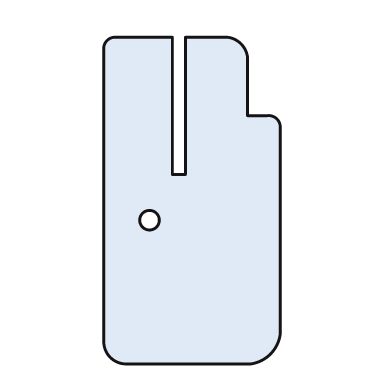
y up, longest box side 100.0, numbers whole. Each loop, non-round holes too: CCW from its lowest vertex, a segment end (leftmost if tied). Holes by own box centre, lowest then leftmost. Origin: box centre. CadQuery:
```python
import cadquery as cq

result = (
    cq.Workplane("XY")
    .moveTo(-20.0, -50.0)
    .lineTo(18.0, -50.0)
    .threePointArc((24.0, -47.0), (27.0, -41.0))
    .lineTo(27.0, 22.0)
    .threePointArc((26.0, 25.0), (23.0, 26.0))
    .lineTo(17.0, 26.0)
    .lineTo(17.0, 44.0)
    .threePointArc((15.0, 48.0), (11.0, 50.0))
    .lineTo(-2.0, 50.0)
    .lineTo(-2.0, 8.0)
    .lineTo(-6.0, 8.0)
    .lineTo(-6.0, 50.0)
    .lineTo(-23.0, 50.0)
    .threePointArc((-26.0, 49.0), (-27.0, 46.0))
    .lineTo(-27.0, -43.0)
    .threePointArc((-25.0, -48.0), (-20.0, -50.0))
    .close()
    .moveTo(-13.0, -6.0)
    .circle(3.0)
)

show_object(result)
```